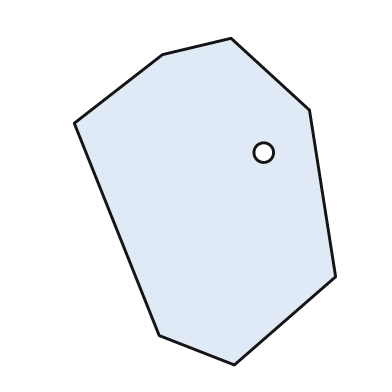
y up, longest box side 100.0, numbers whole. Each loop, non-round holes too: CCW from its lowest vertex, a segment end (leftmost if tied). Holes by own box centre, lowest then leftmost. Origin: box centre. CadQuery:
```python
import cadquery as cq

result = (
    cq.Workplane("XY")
    .moveTo(9.0, -50.0)
    .lineTo(40.0, -23.0)
    .lineTo(32.0, 28.0)
    .lineTo(8.0, 50.0)
    .lineTo(-13.0, 45.0)
    .lineTo(-40.0, 24.0)
    .lineTo(-14.0, -41.0)
    .close()
    .moveTo(18.0, 15.0)
    .circle(3.0)
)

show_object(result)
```